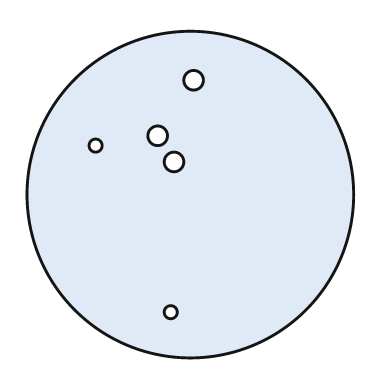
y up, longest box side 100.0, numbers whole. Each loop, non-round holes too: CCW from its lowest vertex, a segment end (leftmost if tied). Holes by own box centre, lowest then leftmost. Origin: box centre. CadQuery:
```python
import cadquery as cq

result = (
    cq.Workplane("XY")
    .moveTo(0.0, 0.0)
    .circle(50.0)
    .moveTo(-6.0, -36.0)
    .circle(2.0)
    .moveTo(-5.0, 10.0)
    .circle(3.0)
    .moveTo(-29.0, 15.0)
    .circle(2.0)
    .moveTo(-10.0, 18.0)
    .circle(3.0)
    .moveTo(1.0, 35.0)
    .circle(3.0)
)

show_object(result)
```